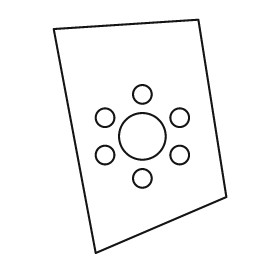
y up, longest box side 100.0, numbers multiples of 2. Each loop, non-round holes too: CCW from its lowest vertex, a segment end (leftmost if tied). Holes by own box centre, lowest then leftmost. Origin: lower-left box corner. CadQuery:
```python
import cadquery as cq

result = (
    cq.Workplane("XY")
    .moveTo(18.0, 0.0)
    .lineTo(74.0, 24.0)
    .lineTo(62.0, 100.0)
    .lineTo(0.0, 96.0)
    .close()
    .moveTo(38.0, 32.0)
    .circle(4.0)
    .moveTo(22.0, 42.0)
    .circle(4.0)
    .moveTo(54.0, 42.0)
    .circle(4.0)
    .moveTo(38.0, 50.0)
    .circle(10.0)
    .moveTo(22.0, 58.0)
    .circle(4.0)
    .moveTo(54.0, 58.0)
    .circle(4.0)
    .moveTo(38.0, 68.0)
    .circle(4.0)
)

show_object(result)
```